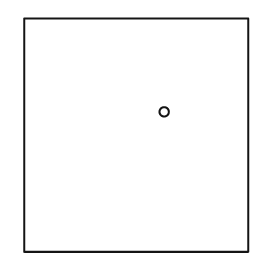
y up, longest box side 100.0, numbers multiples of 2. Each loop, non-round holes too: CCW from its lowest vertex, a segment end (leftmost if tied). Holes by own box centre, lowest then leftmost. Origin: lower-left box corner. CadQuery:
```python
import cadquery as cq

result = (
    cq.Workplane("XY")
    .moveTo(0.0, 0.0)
    .lineTo(96.0, 0.0)
    .lineTo(96.0, 100.0)
    .lineTo(0.0, 100.0)
    .close()
    .moveTo(60.0, 60.0)
    .circle(2.0)
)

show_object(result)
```